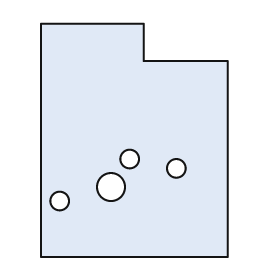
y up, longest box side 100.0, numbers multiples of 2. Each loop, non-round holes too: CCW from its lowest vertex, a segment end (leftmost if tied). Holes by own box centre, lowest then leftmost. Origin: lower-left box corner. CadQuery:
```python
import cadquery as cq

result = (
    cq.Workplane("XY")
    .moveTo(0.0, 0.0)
    .lineTo(80.0, 0.0)
    .lineTo(80.0, 84.0)
    .lineTo(44.0, 84.0)
    .lineTo(44.0, 100.0)
    .lineTo(0.0, 100.0)
    .close()
    .moveTo(8.0, 24.0)
    .circle(4.0)
    .moveTo(30.0, 30.0)
    .circle(6.0)
    .moveTo(58.0, 38.0)
    .circle(4.0)
    .moveTo(38.0, 42.0)
    .circle(4.0)
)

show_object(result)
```